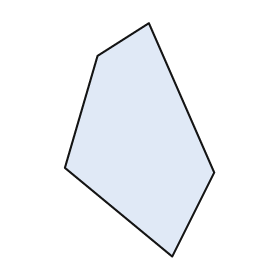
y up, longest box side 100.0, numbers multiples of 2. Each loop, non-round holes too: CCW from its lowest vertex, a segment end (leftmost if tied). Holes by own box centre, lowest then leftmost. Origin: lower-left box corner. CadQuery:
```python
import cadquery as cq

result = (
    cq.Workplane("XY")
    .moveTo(46.0, 0.0)
    .lineTo(64.0, 36.0)
    .lineTo(36.0, 100.0)
    .lineTo(14.0, 86.0)
    .lineTo(0.0, 38.0)
    .close()
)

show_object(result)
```